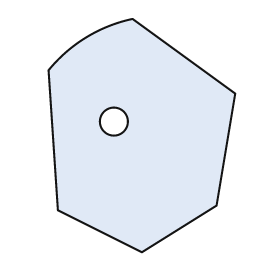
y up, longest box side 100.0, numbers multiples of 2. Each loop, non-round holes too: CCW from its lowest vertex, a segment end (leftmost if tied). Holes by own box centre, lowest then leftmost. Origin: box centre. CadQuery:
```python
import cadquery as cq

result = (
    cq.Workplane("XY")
    .moveTo(0.0, -50.0)
    .lineTo(32.0, -30.0)
    .lineTo(40.0, 18.0)
    .lineTo(-4.0, 50.0)
    .threePointArc((-24.0, 42.0), (-40.0, 28.0))
    .lineTo(-36.0, -32.0)
    .close()
    .moveTo(-12.0, 6.0)
    .circle(6.0)
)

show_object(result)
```